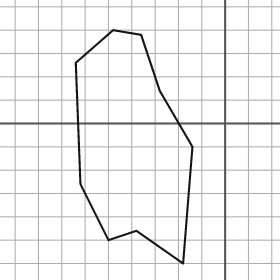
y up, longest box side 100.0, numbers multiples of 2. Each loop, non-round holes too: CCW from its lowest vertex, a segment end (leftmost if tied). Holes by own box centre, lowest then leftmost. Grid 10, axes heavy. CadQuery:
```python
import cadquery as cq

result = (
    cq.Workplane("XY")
    .moveTo(-18.0, -60.0)
    .lineTo(-14.0, -10.0)
    .lineTo(-28.0, 14.0)
    .lineTo(-36.0, 38.0)
    .lineTo(-48.0, 40.0)
    .lineTo(-64.0, 26.0)
    .lineTo(-62.0, -26.0)
    .lineTo(-50.0, -50.0)
    .lineTo(-38.0, -46.0)
    .close()
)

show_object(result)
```